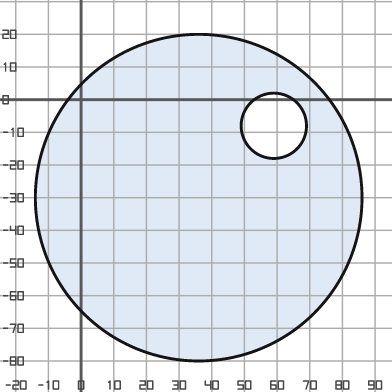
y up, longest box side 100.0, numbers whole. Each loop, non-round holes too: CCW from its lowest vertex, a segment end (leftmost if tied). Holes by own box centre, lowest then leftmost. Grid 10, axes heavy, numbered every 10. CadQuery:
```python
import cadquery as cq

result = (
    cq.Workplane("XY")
    .moveTo(36.0, -30.0)
    .circle(50.0)
    .moveTo(59.0, -8.0)
    .circle(10.0)
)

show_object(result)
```